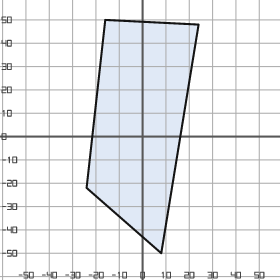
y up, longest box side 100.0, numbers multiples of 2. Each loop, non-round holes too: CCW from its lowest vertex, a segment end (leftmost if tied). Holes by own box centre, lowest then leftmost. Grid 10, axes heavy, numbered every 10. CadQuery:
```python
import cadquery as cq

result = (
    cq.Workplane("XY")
    .moveTo(8.0, -50.0)
    .lineTo(24.0, 48.0)
    .lineTo(-16.0, 50.0)
    .lineTo(-24.0, -22.0)
    .close()
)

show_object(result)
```